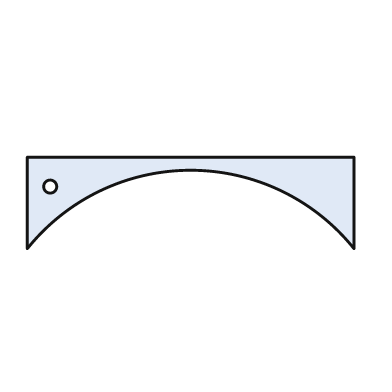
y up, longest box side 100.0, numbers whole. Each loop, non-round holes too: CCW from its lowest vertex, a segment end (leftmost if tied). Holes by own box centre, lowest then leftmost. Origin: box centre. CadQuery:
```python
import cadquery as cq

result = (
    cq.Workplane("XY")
    .moveTo(-50.0, -14.0)
    .threePointArc((0.0, 10.0), (50.0, -14.0))
    .lineTo(50.0, 14.0)
    .lineTo(-50.0, 14.0)
    .close()
    .moveTo(-43.0, 5.0)
    .circle(2.0)
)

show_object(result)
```